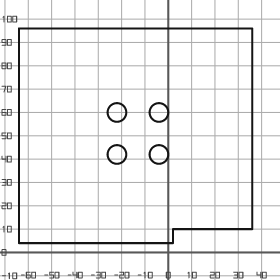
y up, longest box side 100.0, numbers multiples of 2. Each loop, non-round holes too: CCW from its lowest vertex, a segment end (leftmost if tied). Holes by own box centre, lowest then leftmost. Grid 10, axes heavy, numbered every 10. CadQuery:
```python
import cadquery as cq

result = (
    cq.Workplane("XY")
    .moveTo(-64.0, 4.0)
    .lineTo(2.0, 4.0)
    .lineTo(2.0, 10.0)
    .lineTo(36.0, 10.0)
    .lineTo(36.0, 96.0)
    .lineTo(-64.0, 96.0)
    .close()
    .moveTo(-22.0, 42.0)
    .circle(4.0)
    .moveTo(-4.0, 42.0)
    .circle(4.0)
    .moveTo(-22.0, 60.0)
    .circle(4.0)
    .moveTo(-4.0, 60.0)
    .circle(4.0)
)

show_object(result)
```